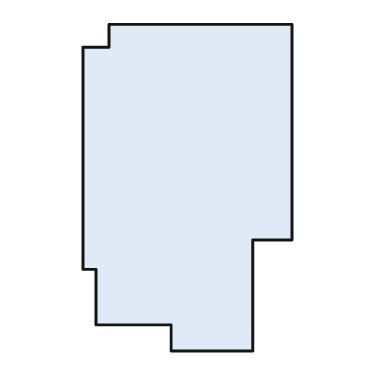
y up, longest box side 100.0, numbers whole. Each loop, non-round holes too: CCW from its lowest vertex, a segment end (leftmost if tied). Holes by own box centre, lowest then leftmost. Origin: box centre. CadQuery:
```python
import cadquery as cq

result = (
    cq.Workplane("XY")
    .moveTo(-5.0, -50.0)
    .lineTo(20.0, -50.0)
    .lineTo(20.0, -16.0)
    .lineTo(32.0, -16.0)
    .lineTo(32.0, 50.0)
    .lineTo(-24.0, 50.0)
    .lineTo(-24.0, 43.0)
    .lineTo(-32.0, 43.0)
    .lineTo(-32.0, -25.0)
    .lineTo(-28.0, -25.0)
    .lineTo(-28.0, -42.0)
    .lineTo(-5.0, -42.0)
    .close()
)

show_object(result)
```